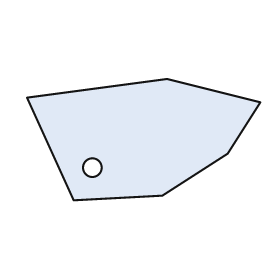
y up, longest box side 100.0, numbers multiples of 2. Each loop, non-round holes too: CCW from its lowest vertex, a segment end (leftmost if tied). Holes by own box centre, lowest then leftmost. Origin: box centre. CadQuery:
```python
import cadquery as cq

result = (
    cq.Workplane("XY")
    .moveTo(-30.0, -26.0)
    .lineTo(8.0, -24.0)
    .lineTo(36.0, -6.0)
    .lineTo(50.0, 16.0)
    .lineTo(10.0, 26.0)
    .lineTo(-50.0, 18.0)
    .close()
    .moveTo(-22.0, -12.0)
    .circle(4.0)
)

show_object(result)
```